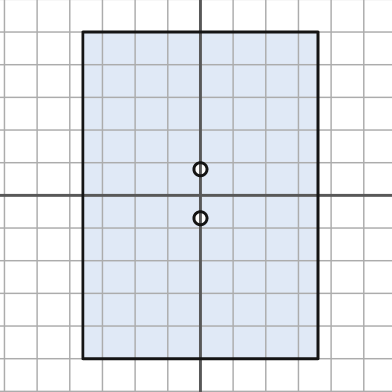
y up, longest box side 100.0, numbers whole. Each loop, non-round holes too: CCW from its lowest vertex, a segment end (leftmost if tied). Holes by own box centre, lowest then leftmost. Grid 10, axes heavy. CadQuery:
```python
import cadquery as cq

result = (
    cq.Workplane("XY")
    .moveTo(-36.0, -50.0)
    .lineTo(36.0, -50.0)
    .lineTo(36.0, 50.0)
    .lineTo(-36.0, 50.0)
    .close()
    .moveTo(0.0, -7.0)
    .circle(2.0)
    .moveTo(0.0, 8.0)
    .circle(2.0)
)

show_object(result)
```